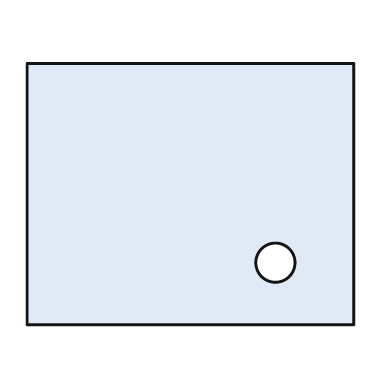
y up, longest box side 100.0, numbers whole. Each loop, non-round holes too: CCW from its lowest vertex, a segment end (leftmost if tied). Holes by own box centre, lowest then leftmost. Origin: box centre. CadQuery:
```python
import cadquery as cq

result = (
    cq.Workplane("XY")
    .moveTo(-50.0, -40.0)
    .lineTo(50.0, -40.0)
    .lineTo(50.0, 40.0)
    .lineTo(-50.0, 40.0)
    .close()
    .moveTo(26.0, -21.0)
    .circle(6.0)
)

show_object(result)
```